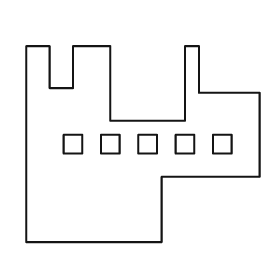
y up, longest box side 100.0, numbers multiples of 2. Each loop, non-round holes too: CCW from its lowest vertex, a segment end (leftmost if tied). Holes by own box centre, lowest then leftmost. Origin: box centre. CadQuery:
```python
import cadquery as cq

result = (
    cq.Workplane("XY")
    .moveTo(-50.0, -42.0)
    .lineTo(8.0, -42.0)
    .lineTo(8.0, -14.0)
    .lineTo(50.0, -14.0)
    .lineTo(50.0, 22.0)
    .lineTo(24.0, 22.0)
    .lineTo(24.0, 42.0)
    .lineTo(18.0, 42.0)
    .lineTo(18.0, 10.0)
    .lineTo(-14.0, 10.0)
    .lineTo(-14.0, 42.0)
    .lineTo(-30.0, 42.0)
    .lineTo(-30.0, 24.0)
    .lineTo(-40.0, 24.0)
    .lineTo(-40.0, 42.0)
    .lineTo(-50.0, 42.0)
    .close()
    .moveTo(-34.0, -4.0)
    .lineTo(-26.0, -4.0)
    .lineTo(-26.0, 4.0)
    .lineTo(-34.0, 4.0)
    .close()
    .moveTo(-18.0, -4.0)
    .lineTo(-10.0, -4.0)
    .lineTo(-10.0, 4.0)
    .lineTo(-18.0, 4.0)
    .close()
    .moveTo(-2.0, -4.0)
    .lineTo(6.0, -4.0)
    .lineTo(6.0, 4.0)
    .lineTo(-2.0, 4.0)
    .close()
    .moveTo(14.0, -4.0)
    .lineTo(22.0, -4.0)
    .lineTo(22.0, 4.0)
    .lineTo(14.0, 4.0)
    .close()
    .moveTo(30.0, -4.0)
    .lineTo(38.0, -4.0)
    .lineTo(38.0, 4.0)
    .lineTo(30.0, 4.0)
    .close()
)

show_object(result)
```